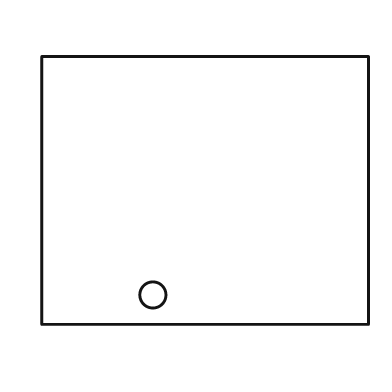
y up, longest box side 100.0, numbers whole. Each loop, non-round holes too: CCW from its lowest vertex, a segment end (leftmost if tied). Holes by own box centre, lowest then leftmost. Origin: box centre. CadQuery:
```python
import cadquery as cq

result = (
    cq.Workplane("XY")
    .moveTo(-50.0, -41.0)
    .lineTo(50.0, -41.0)
    .lineTo(50.0, 41.0)
    .lineTo(-50.0, 41.0)
    .close()
    .moveTo(-16.0, -32.0)
    .circle(4.0)
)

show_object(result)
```